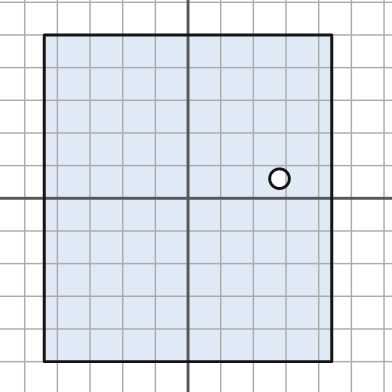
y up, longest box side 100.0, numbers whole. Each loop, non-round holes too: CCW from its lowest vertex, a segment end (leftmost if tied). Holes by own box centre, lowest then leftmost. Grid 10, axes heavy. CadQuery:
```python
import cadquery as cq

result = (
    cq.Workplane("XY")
    .moveTo(-44.0, -50.0)
    .lineTo(44.0, -50.0)
    .lineTo(44.0, 50.0)
    .lineTo(-44.0, 50.0)
    .close()
    .moveTo(28.0, 6.0)
    .circle(3.0)
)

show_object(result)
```